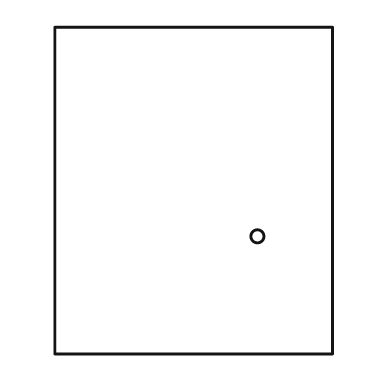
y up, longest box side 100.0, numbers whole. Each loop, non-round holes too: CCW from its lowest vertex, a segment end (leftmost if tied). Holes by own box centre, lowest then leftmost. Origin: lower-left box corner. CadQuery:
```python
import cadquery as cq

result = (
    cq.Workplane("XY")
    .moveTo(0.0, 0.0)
    .lineTo(85.0, 0.0)
    .lineTo(85.0, 100.0)
    .lineTo(0.0, 100.0)
    .close()
    .moveTo(62.0, 36.0)
    .circle(2.0)
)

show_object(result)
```